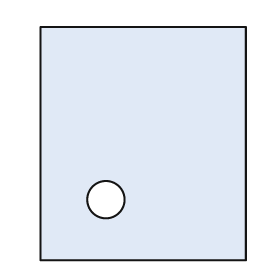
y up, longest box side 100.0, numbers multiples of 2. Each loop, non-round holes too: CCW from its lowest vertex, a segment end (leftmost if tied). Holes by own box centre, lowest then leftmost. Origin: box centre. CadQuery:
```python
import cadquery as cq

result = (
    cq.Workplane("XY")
    .moveTo(-44.0, -50.0)
    .lineTo(44.0, -50.0)
    .lineTo(44.0, 50.0)
    .lineTo(-44.0, 50.0)
    .close()
    .moveTo(-16.0, -24.0)
    .circle(8.0)
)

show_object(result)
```